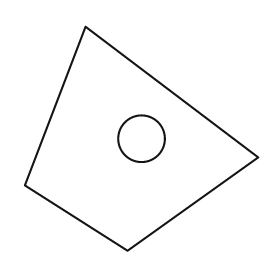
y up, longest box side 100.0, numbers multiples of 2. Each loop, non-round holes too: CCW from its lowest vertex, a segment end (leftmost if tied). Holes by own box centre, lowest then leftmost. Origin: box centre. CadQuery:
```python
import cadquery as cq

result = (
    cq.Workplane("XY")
    .moveTo(-6.0, -48.0)
    .lineTo(50.0, -8.0)
    .lineTo(-24.0, 48.0)
    .lineTo(-50.0, -20.0)
    .close()
    .moveTo(0.0, 0.0)
    .circle(10.0)
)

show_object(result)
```